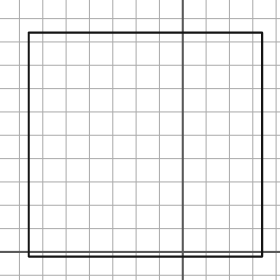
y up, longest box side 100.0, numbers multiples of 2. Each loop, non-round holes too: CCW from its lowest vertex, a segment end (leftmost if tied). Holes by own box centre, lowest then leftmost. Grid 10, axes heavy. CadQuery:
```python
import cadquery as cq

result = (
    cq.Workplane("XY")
    .moveTo(-66.0, -2.0)
    .lineTo(34.0, -2.0)
    .lineTo(34.0, 94.0)
    .lineTo(-66.0, 94.0)
    .close()
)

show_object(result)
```